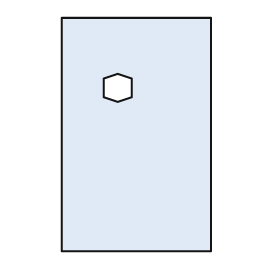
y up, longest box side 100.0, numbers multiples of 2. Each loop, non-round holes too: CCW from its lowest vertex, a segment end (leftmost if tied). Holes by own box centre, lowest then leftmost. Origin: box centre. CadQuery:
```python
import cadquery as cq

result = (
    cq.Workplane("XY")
    .moveTo(-32.0, -50.0)
    .lineTo(32.0, -50.0)
    .lineTo(32.0, 50.0)
    .lineTo(-32.0, 50.0)
    .close()
    .moveTo(-8.0, 14.0)
    .lineTo(-2.0, 16.0)
    .lineTo(-2.0, 24.0)
    .lineTo(-8.0, 26.0)
    .lineTo(-14.0, 24.0)
    .lineTo(-14.0, 16.0)
    .close()
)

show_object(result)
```